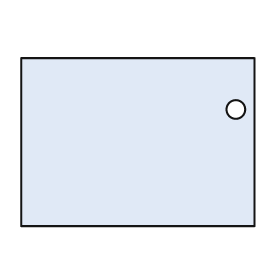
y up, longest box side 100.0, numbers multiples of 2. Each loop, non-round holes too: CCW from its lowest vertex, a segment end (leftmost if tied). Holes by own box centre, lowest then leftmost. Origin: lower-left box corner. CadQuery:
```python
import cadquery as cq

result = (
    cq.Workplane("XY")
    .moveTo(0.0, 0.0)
    .lineTo(100.0, 0.0)
    .lineTo(100.0, 72.0)
    .lineTo(0.0, 72.0)
    .close()
    .moveTo(92.0, 50.0)
    .circle(4.0)
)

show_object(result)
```